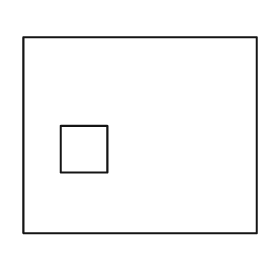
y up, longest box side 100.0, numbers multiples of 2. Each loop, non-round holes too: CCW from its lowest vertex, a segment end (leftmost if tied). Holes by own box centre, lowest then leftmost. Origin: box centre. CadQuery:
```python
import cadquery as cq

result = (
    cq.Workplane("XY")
    .moveTo(-50.0, -42.0)
    .lineTo(50.0, -42.0)
    .lineTo(50.0, 42.0)
    .lineTo(-50.0, 42.0)
    .close()
    .moveTo(-34.0, -16.0)
    .lineTo(-14.0, -16.0)
    .lineTo(-14.0, 4.0)
    .lineTo(-34.0, 4.0)
    .close()
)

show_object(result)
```